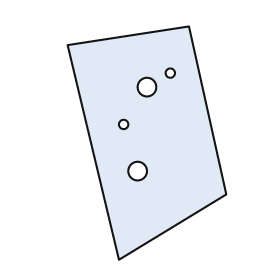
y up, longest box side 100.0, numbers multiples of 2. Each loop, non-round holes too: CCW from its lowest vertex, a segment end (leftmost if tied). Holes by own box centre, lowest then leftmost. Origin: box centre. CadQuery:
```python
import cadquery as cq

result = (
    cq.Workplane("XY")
    .moveTo(-12.0, -50.0)
    .lineTo(34.0, -22.0)
    .lineTo(18.0, 50.0)
    .lineTo(-34.0, 42.0)
    .close()
    .moveTo(-4.0, -12.0)
    .circle(4.0)
    .moveTo(-10.0, 8.0)
    .circle(2.0)
    .moveTo(0.0, 24.0)
    .circle(4.0)
    .moveTo(10.0, 30.0)
    .circle(2.0)
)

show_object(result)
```